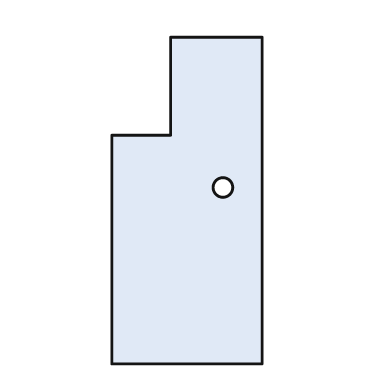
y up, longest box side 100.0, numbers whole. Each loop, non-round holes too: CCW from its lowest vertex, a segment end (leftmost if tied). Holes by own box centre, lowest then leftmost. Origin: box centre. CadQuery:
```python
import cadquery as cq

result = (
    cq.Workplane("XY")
    .moveTo(-23.0, -50.0)
    .lineTo(23.0, -50.0)
    .lineTo(23.0, 50.0)
    .lineTo(-5.0, 50.0)
    .lineTo(-5.0, 20.0)
    .lineTo(-23.0, 20.0)
    .close()
    .moveTo(11.0, 4.0)
    .circle(3.0)
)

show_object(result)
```